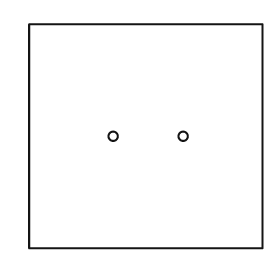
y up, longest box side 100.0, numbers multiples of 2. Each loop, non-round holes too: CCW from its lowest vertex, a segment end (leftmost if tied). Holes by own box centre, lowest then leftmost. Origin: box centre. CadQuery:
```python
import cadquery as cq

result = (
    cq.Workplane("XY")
    .moveTo(-50.0, -48.0)
    .lineTo(50.0, -48.0)
    .lineTo(50.0, 48.0)
    .lineTo(-50.0, 48.0)
    .close()
    .moveTo(-14.0, 0.0)
    .circle(2.0)
    .moveTo(16.0, 0.0)
    .circle(2.0)
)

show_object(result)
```